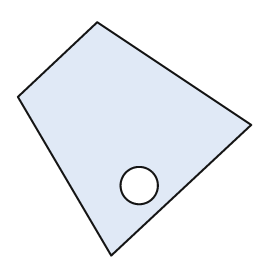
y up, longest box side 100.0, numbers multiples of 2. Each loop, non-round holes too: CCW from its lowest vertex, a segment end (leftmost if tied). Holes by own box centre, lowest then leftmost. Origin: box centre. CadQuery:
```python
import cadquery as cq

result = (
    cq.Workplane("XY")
    .moveTo(-10.0, -50.0)
    .lineTo(50.0, 6.0)
    .lineTo(-16.0, 50.0)
    .lineTo(-50.0, 18.0)
    .close()
    .moveTo(2.0, -20.0)
    .circle(8.0)
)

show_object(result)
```